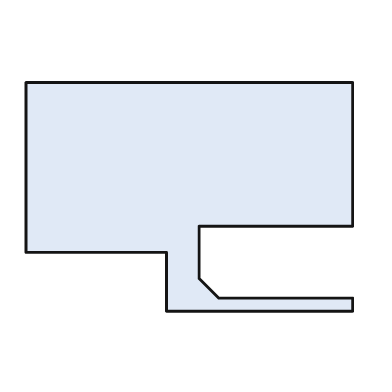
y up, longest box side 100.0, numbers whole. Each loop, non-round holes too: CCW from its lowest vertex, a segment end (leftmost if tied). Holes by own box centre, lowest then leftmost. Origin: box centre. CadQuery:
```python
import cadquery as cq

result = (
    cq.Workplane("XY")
    .moveTo(-7.0, -35.0)
    .lineTo(50.0, -35.0)
    .lineTo(50.0, -31.0)
    .lineTo(9.0, -31.0)
    .lineTo(3.0, -25.0)
    .lineTo(3.0, -9.0)
    .lineTo(50.0, -9.0)
    .lineTo(50.0, 35.0)
    .lineTo(-50.0, 35.0)
    .lineTo(-50.0, -17.0)
    .lineTo(-7.0, -17.0)
    .close()
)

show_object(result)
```